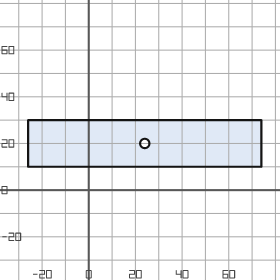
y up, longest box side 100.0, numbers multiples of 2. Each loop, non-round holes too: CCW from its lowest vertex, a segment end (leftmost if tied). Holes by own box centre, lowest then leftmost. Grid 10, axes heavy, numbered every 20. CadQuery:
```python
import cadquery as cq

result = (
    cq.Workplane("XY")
    .moveTo(-26.0, 10.0)
    .lineTo(74.0, 10.0)
    .lineTo(74.0, 30.0)
    .lineTo(-26.0, 30.0)
    .close()
    .moveTo(24.0, 20.0)
    .circle(2.0)
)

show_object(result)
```